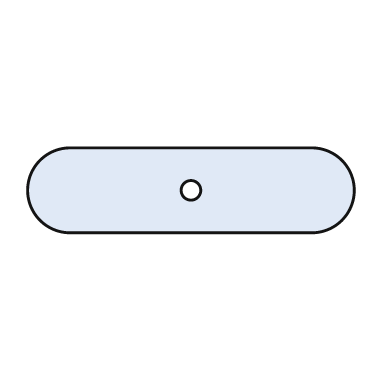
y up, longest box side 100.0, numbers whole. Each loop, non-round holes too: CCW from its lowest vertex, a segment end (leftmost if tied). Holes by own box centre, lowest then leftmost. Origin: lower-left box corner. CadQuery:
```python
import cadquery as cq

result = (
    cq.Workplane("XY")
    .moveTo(13.0, 0.0)
    .lineTo(87.0, 0.0)
    .threePointArc((100.0, 13.0), (87.0, 26.0))
    .lineTo(13.0, 26.0)
    .threePointArc((0.0, 13.0), (13.0, 0.0))
    .close()
    .moveTo(50.0, 13.0)
    .circle(3.0)
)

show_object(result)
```